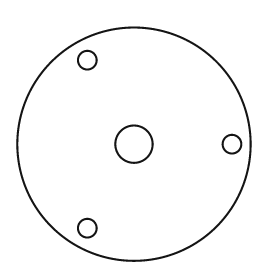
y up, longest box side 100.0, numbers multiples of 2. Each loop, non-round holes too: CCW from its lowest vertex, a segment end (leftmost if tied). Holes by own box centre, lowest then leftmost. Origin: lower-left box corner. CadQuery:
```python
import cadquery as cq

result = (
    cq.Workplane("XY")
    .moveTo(50.0, 50.0)
    .circle(50.0)
    .moveTo(30.0, 14.0)
    .circle(4.0)
    .moveTo(50.0, 50.0)
    .circle(8.0)
    .moveTo(92.0, 50.0)
    .circle(4.0)
    .moveTo(30.0, 86.0)
    .circle(4.0)
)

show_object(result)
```